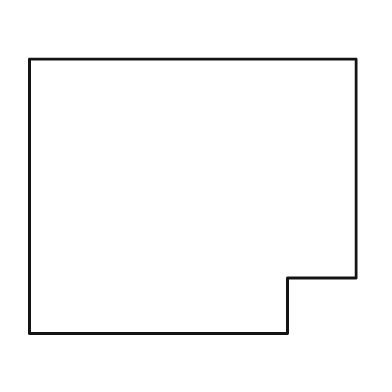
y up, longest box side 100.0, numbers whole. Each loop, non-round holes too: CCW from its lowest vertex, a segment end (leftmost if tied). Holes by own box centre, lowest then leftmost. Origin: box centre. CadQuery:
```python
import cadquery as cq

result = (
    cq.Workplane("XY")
    .moveTo(-50.0, -42.0)
    .lineTo(29.0, -42.0)
    .lineTo(29.0, -25.0)
    .lineTo(50.0, -25.0)
    .lineTo(50.0, 42.0)
    .lineTo(-50.0, 42.0)
    .close()
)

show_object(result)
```